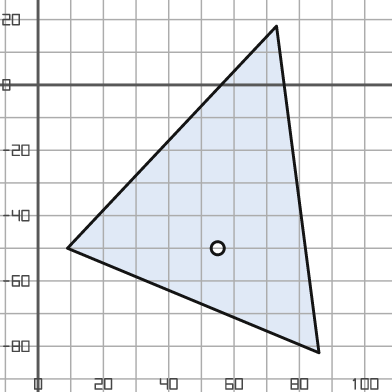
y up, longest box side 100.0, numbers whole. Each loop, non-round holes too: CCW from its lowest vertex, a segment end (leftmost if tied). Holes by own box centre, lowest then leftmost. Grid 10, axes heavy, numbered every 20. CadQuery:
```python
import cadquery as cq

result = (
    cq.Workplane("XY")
    .moveTo(86.0, -82.0)
    .lineTo(73.0, 18.0)
    .lineTo(9.0, -50.0)
    .close()
    .moveTo(55.0, -50.0)
    .circle(2.0)
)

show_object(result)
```